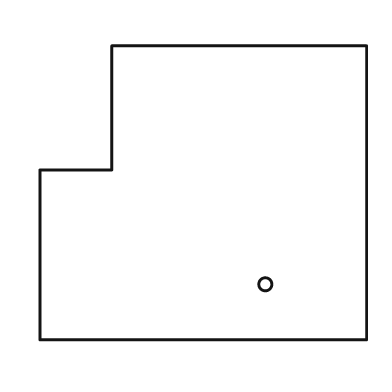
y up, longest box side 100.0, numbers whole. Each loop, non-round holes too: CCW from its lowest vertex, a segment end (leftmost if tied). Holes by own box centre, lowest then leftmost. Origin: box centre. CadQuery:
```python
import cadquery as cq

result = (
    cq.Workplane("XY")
    .moveTo(-50.0, -45.0)
    .lineTo(50.0, -45.0)
    .lineTo(50.0, 45.0)
    .lineTo(-28.0, 45.0)
    .lineTo(-28.0, 7.0)
    .lineTo(-50.0, 7.0)
    .close()
    .moveTo(19.0, -28.0)
    .circle(2.0)
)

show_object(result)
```